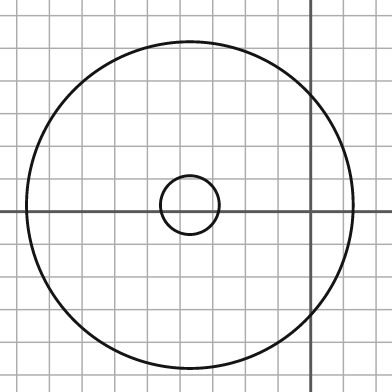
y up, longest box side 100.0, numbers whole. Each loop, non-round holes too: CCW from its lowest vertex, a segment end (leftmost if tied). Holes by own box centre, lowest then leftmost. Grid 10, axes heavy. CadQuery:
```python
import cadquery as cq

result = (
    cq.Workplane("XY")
    .moveTo(-37.0, 2.0)
    .circle(50.0)
    .moveTo(-37.0, 2.0)
    .circle(9.0)
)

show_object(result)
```